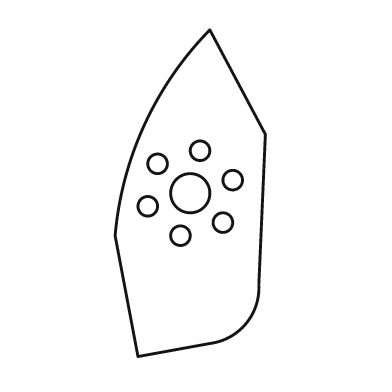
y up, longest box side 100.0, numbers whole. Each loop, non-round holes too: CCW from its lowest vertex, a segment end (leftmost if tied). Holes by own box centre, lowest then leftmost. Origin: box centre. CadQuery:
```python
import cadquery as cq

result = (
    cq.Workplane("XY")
    .moveTo(-16.0, -50.0)
    .lineTo(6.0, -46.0)
    .threePointArc((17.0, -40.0), (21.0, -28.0))
    .lineTo(23.0, 18.0)
    .lineTo(6.0, 50.0)
    .threePointArc((-14.0, 21.0), (-23.0, -13.0))
    .close()
    .moveTo(-3.0, -13.0)
    .circle(3.0)
    .moveTo(10.0, -9.0)
    .circle(3.0)
    .moveTo(-13.0, -4.0)
    .circle(3.0)
    .moveTo(0.0, 0.0)
    .circle(6.0)
    .moveTo(13.0, 4.0)
    .circle(3.0)
    .moveTo(-10.0, 9.0)
    .circle(3.0)
    .moveTo(3.0, 13.0)
    .circle(3.0)
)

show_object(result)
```